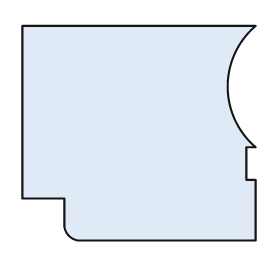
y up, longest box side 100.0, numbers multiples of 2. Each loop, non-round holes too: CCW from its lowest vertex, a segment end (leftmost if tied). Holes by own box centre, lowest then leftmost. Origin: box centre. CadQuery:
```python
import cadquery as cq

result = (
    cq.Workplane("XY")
    .moveTo(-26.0, -46.0)
    .lineTo(50.0, -46.0)
    .lineTo(50.0, -20.0)
    .lineTo(46.0, -20.0)
    .lineTo(46.0, -6.0)
    .lineTo(50.0, -6.0)
    .threePointArc((38.0, 20.0), (50.0, 46.0))
    .lineTo(-50.0, 46.0)
    .lineTo(-50.0, -28.0)
    .lineTo(-32.0, -28.0)
    .lineTo(-32.0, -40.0)
    .threePointArc((-30.0, -44.0), (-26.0, -46.0))
    .close()
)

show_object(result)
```